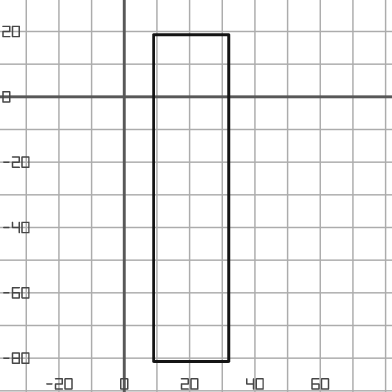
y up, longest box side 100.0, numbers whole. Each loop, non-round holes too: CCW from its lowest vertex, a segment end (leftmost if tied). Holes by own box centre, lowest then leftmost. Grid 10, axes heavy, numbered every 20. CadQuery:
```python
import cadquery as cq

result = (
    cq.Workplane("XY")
    .moveTo(9.0, -81.0)
    .lineTo(32.0, -81.0)
    .lineTo(32.0, 19.0)
    .lineTo(9.0, 19.0)
    .close()
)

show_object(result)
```